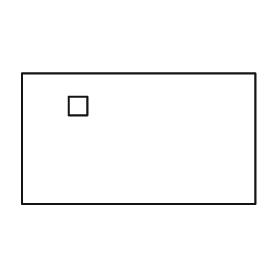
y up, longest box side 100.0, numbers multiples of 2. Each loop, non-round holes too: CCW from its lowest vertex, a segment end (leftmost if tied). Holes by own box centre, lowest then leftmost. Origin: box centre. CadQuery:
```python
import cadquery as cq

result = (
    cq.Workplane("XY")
    .moveTo(-50.0, -28.0)
    .lineTo(50.0, -28.0)
    .lineTo(50.0, 28.0)
    .lineTo(-50.0, 28.0)
    .close()
    .moveTo(-30.0, 10.0)
    .lineTo(-22.0, 10.0)
    .lineTo(-22.0, 18.0)
    .lineTo(-30.0, 18.0)
    .close()
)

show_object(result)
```